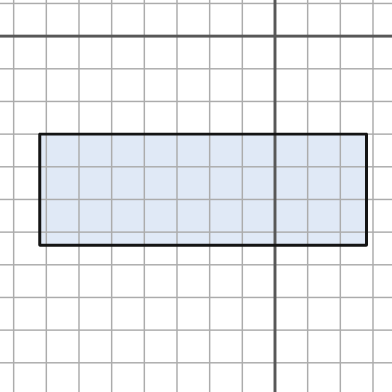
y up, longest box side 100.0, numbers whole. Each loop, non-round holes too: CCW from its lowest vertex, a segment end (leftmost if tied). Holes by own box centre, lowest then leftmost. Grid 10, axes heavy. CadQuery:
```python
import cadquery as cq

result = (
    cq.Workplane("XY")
    .moveTo(-72.0, -64.0)
    .lineTo(28.0, -64.0)
    .lineTo(28.0, -30.0)
    .lineTo(-72.0, -30.0)
    .close()
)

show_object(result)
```